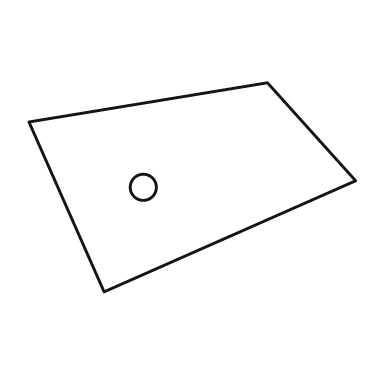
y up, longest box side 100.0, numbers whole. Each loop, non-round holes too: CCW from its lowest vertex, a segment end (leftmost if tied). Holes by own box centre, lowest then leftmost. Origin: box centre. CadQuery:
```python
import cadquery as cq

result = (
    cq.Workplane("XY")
    .moveTo(-27.0, -32.0)
    .lineTo(50.0, 2.0)
    .lineTo(23.0, 32.0)
    .lineTo(-50.0, 20.0)
    .close()
    .moveTo(-15.0, 0.0)
    .circle(4.0)
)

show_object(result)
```